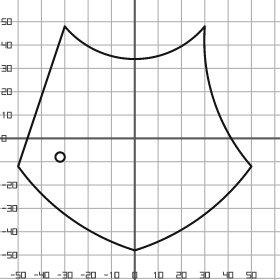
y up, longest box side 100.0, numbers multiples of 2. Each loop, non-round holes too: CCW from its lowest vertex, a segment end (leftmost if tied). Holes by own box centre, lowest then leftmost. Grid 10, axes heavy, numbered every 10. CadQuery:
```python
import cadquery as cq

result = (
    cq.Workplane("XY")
    .moveTo(0.0, -48.0)
    .threePointArc((28.0, -34.0), (50.0, -12.0))
    .threePointArc((34.0, 16.0), (30.0, 48.0))
    .threePointArc((0.0, 34.0), (-30.0, 48.0))
    .lineTo(-50.0, -12.0)
    .threePointArc((-28.0, -34.0), (0.0, -48.0))
    .close()
    .moveTo(-32.0, -8.0)
    .circle(2.0)
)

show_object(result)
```